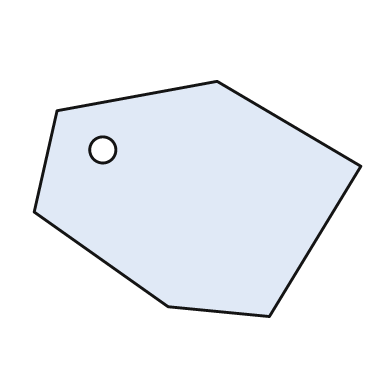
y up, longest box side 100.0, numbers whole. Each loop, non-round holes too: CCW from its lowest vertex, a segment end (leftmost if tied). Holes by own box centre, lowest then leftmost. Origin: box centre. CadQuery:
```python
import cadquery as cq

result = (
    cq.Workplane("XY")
    .moveTo(22.0, -36.0)
    .lineTo(50.0, 10.0)
    .lineTo(6.0, 36.0)
    .lineTo(-43.0, 27.0)
    .lineTo(-50.0, -4.0)
    .lineTo(-9.0, -33.0)
    .close()
    .moveTo(-29.0, 15.0)
    .circle(4.0)
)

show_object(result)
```